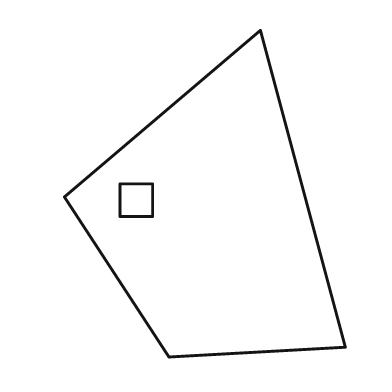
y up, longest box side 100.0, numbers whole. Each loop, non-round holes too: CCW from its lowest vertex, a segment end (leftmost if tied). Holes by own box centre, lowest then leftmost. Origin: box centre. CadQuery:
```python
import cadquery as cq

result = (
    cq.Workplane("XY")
    .moveTo(-11.0, -50.0)
    .lineTo(43.0, -47.0)
    .lineTo(17.0, 50.0)
    .lineTo(-43.0, -1.0)
    .close()
    .moveTo(-26.0, -7.0)
    .lineTo(-16.0, -7.0)
    .lineTo(-16.0, 3.0)
    .lineTo(-26.0, 3.0)
    .close()
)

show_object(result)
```